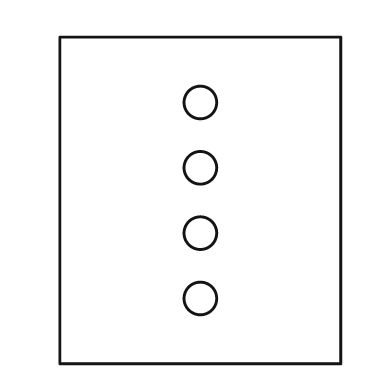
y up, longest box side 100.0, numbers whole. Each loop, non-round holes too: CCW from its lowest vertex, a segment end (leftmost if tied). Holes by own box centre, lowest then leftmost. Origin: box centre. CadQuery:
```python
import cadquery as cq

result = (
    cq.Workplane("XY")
    .moveTo(-43.0, -50.0)
    .lineTo(43.0, -50.0)
    .lineTo(43.0, 50.0)
    .lineTo(-43.0, 50.0)
    .close()
    .moveTo(0.0, -30.0)
    .circle(5.0)
    .moveTo(0.0, -10.0)
    .circle(5.0)
    .moveTo(0.0, 10.0)
    .circle(5.0)
    .moveTo(0.0, 30.0)
    .circle(5.0)
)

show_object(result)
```